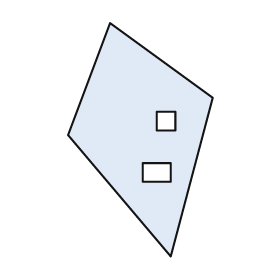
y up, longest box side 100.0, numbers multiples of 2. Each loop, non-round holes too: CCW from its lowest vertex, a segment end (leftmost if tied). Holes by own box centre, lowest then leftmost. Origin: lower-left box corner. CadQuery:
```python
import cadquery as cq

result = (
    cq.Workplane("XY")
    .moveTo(44.0, 0.0)
    .lineTo(62.0, 68.0)
    .lineTo(18.0, 100.0)
    .lineTo(0.0, 52.0)
    .close()
    .moveTo(32.0, 32.0)
    .lineTo(44.0, 32.0)
    .lineTo(44.0, 40.0)
    .lineTo(32.0, 40.0)
    .close()
    .moveTo(38.0, 54.0)
    .lineTo(46.0, 54.0)
    .lineTo(46.0, 62.0)
    .lineTo(38.0, 62.0)
    .close()
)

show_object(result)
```